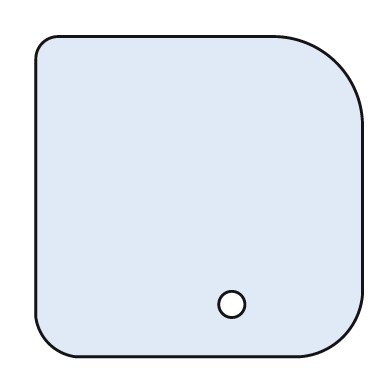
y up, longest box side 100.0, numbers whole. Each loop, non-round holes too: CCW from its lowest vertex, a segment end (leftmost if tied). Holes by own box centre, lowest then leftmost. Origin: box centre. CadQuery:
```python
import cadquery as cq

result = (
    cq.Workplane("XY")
    .moveTo(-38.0, -49.0)
    .lineTo(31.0, -49.0)
    .threePointArc((44.0, -43.0), (50.0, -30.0))
    .lineTo(50.0, 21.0)
    .threePointArc((42.0, 41.0), (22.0, 49.0))
    .lineTo(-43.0, 49.0)
    .threePointArc((-48.0, 47.0), (-50.0, 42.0))
    .lineTo(-50.0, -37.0)
    .threePointArc((-46.0, -45.0), (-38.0, -49.0))
    .close()
    .moveTo(10.0, -33.0)
    .circle(4.0)
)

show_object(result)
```